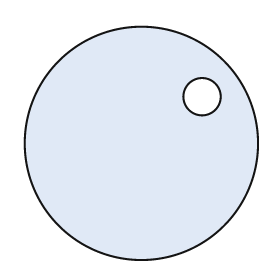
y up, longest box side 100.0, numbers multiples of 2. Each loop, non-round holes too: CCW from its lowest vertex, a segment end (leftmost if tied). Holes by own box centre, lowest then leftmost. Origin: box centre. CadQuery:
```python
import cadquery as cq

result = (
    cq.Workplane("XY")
    .moveTo(0.0, 0.0)
    .circle(50.0)
    .moveTo(26.0, 20.0)
    .circle(8.0)
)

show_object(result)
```